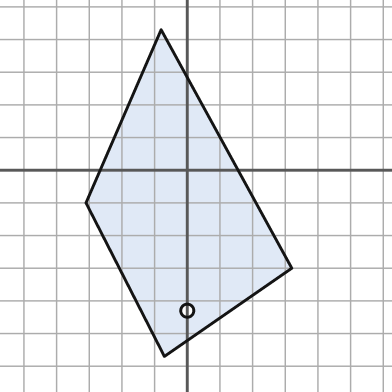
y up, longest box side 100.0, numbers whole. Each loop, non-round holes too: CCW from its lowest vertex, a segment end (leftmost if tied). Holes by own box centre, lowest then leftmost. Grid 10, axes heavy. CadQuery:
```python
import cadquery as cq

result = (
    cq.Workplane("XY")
    .moveTo(-7.0, -57.0)
    .lineTo(32.0, -30.0)
    .lineTo(-8.0, 43.0)
    .lineTo(-31.0, -10.0)
    .close()
    .moveTo(0.0, -43.0)
    .circle(2.0)
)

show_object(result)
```